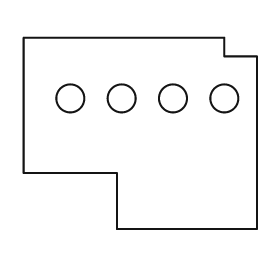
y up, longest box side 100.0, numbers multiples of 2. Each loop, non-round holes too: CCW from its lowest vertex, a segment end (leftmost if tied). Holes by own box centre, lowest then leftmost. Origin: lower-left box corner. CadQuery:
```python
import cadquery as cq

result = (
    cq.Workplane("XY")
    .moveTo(40.0, 0.0)
    .lineTo(100.0, 0.0)
    .lineTo(100.0, 74.0)
    .lineTo(86.0, 74.0)
    .lineTo(86.0, 82.0)
    .lineTo(0.0, 82.0)
    .lineTo(0.0, 24.0)
    .lineTo(40.0, 24.0)
    .close()
    .moveTo(20.0, 56.0)
    .circle(6.0)
    .moveTo(42.0, 56.0)
    .circle(6.0)
    .moveTo(64.0, 56.0)
    .circle(6.0)
    .moveTo(86.0, 56.0)
    .circle(6.0)
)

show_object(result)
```